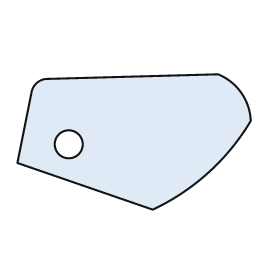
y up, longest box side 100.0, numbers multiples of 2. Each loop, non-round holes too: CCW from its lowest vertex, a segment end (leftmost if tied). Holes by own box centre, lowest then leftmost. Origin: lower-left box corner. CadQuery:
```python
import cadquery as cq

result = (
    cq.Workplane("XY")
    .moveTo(58.0, 0.0)
    .threePointArc((82.0, 16.0), (100.0, 38.0))
    .threePointArc((96.0, 50.0), (86.0, 58.0))
    .lineTo(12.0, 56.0)
    .threePointArc((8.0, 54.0), (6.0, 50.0))
    .lineTo(0.0, 20.0)
    .close()
    .moveTo(22.0, 28.0)
    .circle(6.0)
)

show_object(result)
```